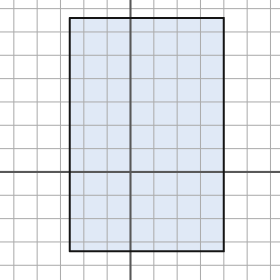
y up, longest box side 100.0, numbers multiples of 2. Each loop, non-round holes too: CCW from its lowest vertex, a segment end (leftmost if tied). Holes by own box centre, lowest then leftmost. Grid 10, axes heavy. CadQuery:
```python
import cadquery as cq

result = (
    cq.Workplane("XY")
    .moveTo(-26.0, -34.0)
    .lineTo(40.0, -34.0)
    .lineTo(40.0, 66.0)
    .lineTo(-26.0, 66.0)
    .close()
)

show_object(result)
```